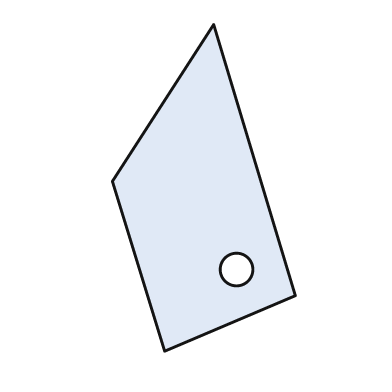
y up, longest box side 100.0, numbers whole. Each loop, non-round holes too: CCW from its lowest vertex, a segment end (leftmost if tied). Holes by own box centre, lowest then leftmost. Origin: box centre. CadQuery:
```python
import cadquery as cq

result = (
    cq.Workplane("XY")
    .moveTo(-12.0, -50.0)
    .lineTo(28.0, -33.0)
    .lineTo(3.0, 50.0)
    .lineTo(-28.0, 2.0)
    .close()
    .moveTo(10.0, -25.0)
    .circle(5.0)
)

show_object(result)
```